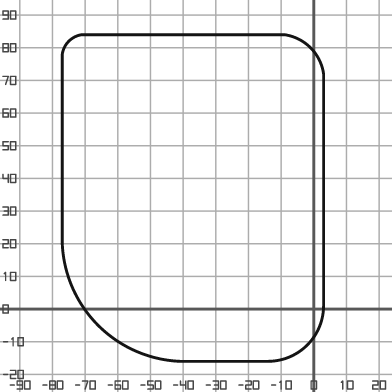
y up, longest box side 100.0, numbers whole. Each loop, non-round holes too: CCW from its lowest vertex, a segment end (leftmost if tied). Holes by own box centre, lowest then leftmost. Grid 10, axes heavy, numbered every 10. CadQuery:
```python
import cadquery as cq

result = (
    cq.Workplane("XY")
    .moveTo(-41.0, -16.0)
    .lineTo(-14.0, -16.0)
    .threePointArc((-2.0, -11.0), (3.0, 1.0))
    .lineTo(3.0, 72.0)
    .threePointArc((-1.0, 80.0), (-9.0, 84.0))
    .lineTo(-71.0, 84.0)
    .threePointArc((-75.0, 82.0), (-77.0, 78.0))
    .lineTo(-77.0, 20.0)
    .threePointArc((-66.0, -5.0), (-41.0, -16.0))
    .close()
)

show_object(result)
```